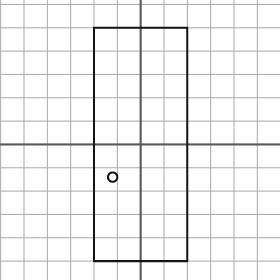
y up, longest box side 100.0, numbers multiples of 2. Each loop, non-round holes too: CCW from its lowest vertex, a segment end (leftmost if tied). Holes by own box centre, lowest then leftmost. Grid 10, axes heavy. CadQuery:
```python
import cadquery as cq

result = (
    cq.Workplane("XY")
    .moveTo(-20.0, -50.0)
    .lineTo(20.0, -50.0)
    .lineTo(20.0, 50.0)
    .lineTo(-20.0, 50.0)
    .close()
    .moveTo(-12.0, -14.0)
    .circle(2.0)
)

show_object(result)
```